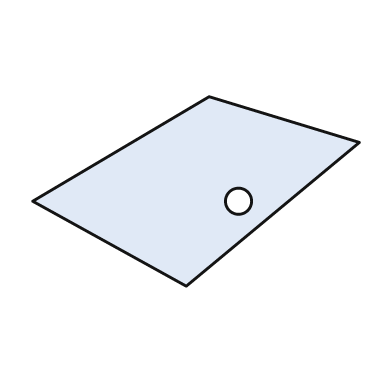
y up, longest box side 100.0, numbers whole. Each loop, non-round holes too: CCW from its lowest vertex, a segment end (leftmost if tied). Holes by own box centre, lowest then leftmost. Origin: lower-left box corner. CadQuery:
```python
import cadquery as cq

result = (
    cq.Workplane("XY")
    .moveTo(47.0, 0.0)
    .lineTo(100.0, 44.0)
    .lineTo(54.0, 58.0)
    .lineTo(0.0, 26.0)
    .close()
    .moveTo(63.0, 26.0)
    .circle(4.0)
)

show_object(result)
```